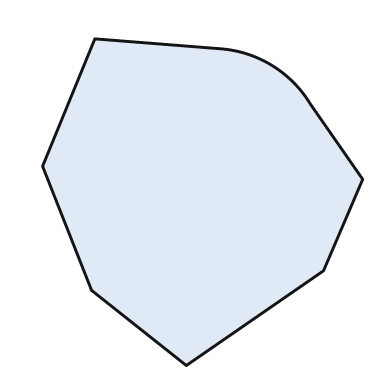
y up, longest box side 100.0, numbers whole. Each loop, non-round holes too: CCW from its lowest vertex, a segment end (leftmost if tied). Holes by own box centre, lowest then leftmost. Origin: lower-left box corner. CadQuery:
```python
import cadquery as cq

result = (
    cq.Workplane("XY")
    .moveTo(44.0, 0.0)
    .lineTo(86.0, 29.0)
    .lineTo(98.0, 57.0)
    .lineTo(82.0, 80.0)
    .threePointArc((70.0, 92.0), (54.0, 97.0))
    .lineTo(16.0, 100.0)
    .lineTo(0.0, 61.0)
    .lineTo(15.0, 23.0)
    .close()
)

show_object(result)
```